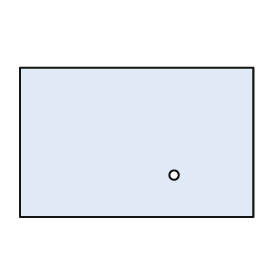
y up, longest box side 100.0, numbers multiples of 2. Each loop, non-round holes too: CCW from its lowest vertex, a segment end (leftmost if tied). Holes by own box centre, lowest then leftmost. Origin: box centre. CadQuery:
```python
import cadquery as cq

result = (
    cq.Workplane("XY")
    .moveTo(-50.0, -32.0)
    .lineTo(50.0, -32.0)
    .lineTo(50.0, 32.0)
    .lineTo(-50.0, 32.0)
    .close()
    .moveTo(16.0, -14.0)
    .circle(2.0)
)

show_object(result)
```